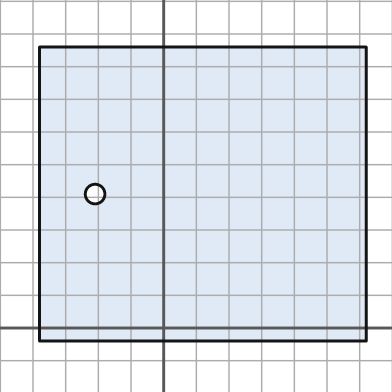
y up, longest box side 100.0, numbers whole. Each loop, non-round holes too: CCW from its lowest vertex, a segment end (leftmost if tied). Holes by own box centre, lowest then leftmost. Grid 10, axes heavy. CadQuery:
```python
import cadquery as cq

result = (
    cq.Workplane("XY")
    .moveTo(-38.0, -4.0)
    .lineTo(62.0, -4.0)
    .lineTo(62.0, 86.0)
    .lineTo(-38.0, 86.0)
    .close()
    .moveTo(-21.0, 41.0)
    .circle(3.0)
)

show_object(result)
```